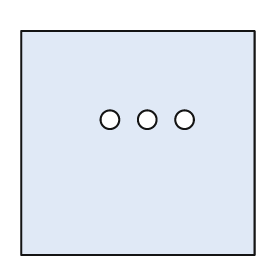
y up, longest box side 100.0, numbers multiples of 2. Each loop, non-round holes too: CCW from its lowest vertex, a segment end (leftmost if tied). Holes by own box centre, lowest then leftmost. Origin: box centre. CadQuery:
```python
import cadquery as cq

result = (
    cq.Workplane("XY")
    .moveTo(-50.0, -48.0)
    .lineTo(50.0, -48.0)
    .lineTo(50.0, 48.0)
    .lineTo(-50.0, 48.0)
    .close()
    .moveTo(-12.0, 10.0)
    .circle(4.0)
    .moveTo(4.0, 10.0)
    .circle(4.0)
    .moveTo(20.0, 10.0)
    .circle(4.0)
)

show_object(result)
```